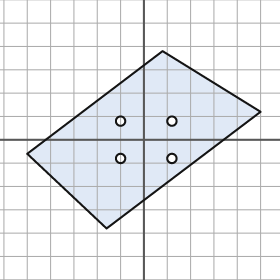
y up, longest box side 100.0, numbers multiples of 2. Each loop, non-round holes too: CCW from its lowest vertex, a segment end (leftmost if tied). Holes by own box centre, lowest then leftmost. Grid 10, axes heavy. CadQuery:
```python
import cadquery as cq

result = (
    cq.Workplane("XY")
    .moveTo(-16.0, -38.0)
    .lineTo(50.0, 12.0)
    .lineTo(8.0, 38.0)
    .lineTo(-50.0, -6.0)
    .close()
    .moveTo(-10.0, -8.0)
    .circle(2.0)
    .moveTo(12.0, -8.0)
    .circle(2.0)
    .moveTo(-10.0, 8.0)
    .circle(2.0)
    .moveTo(12.0, 8.0)
    .circle(2.0)
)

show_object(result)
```